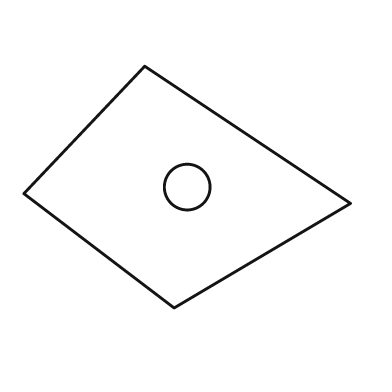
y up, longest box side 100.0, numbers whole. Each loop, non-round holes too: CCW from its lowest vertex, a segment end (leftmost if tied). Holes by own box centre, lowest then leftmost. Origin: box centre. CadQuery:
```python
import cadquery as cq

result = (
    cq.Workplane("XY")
    .moveTo(-4.0, -37.0)
    .lineTo(50.0, -5.0)
    .lineTo(-13.0, 37.0)
    .lineTo(-50.0, -2.0)
    .close()
    .moveTo(0.0, 0.0)
    .circle(7.0)
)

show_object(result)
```